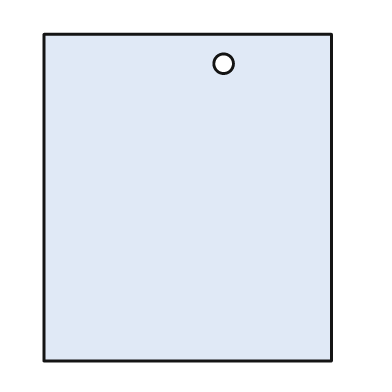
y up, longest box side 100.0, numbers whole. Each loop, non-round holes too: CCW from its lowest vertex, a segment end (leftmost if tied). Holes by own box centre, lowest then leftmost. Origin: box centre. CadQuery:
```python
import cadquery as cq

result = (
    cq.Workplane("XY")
    .moveTo(-44.0, -50.0)
    .lineTo(44.0, -50.0)
    .lineTo(44.0, 50.0)
    .lineTo(-44.0, 50.0)
    .close()
    .moveTo(11.0, 41.0)
    .circle(3.0)
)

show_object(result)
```